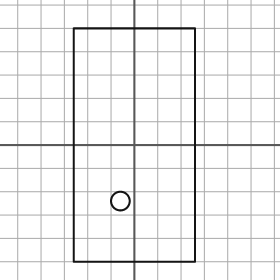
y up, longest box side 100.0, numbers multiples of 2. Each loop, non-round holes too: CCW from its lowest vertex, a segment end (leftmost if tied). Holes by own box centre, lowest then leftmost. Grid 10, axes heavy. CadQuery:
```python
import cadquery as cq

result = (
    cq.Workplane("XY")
    .moveTo(-26.0, -50.0)
    .lineTo(26.0, -50.0)
    .lineTo(26.0, 50.0)
    .lineTo(-26.0, 50.0)
    .close()
    .moveTo(-6.0, -24.0)
    .circle(4.0)
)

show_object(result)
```